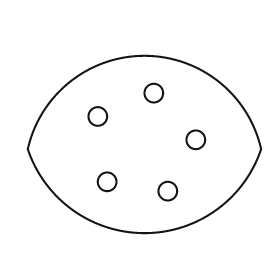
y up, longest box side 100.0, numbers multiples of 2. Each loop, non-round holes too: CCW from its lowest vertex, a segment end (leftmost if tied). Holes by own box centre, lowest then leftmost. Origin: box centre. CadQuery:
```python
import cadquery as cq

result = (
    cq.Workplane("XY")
    .moveTo(-50.0, -2.0)
    .threePointArc((0.0, -38.0), (50.0, -2.0))
    .threePointArc((0.0, 38.0), (-50.0, -2.0))
    .close()
    .moveTo(10.0, -20.0)
    .circle(4.0)
    .moveTo(-16.0, -16.0)
    .circle(4.0)
    .moveTo(22.0, 2.0)
    .circle(4.0)
    .moveTo(-20.0, 12.0)
    .circle(4.0)
    .moveTo(4.0, 22.0)
    .circle(4.0)
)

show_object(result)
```